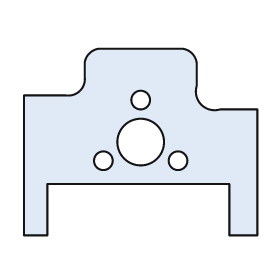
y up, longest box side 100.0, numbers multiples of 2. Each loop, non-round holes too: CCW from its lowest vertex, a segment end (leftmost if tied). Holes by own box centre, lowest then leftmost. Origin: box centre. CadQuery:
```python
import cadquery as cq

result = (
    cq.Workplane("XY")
    .moveTo(-50.0, -40.0)
    .lineTo(-40.0, -40.0)
    .lineTo(-40.0, -18.0)
    .lineTo(38.0, -18.0)
    .lineTo(38.0, -40.0)
    .lineTo(50.0, -40.0)
    .lineTo(50.0, 14.0)
    .lineTo(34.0, 14.0)
    .threePointArc((26.0, 16.0), (24.0, 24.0))
    .lineTo(24.0, 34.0)
    .threePointArc((22.0, 38.0), (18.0, 40.0))
    .lineTo(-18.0, 40.0)
    .threePointArc((-22.0, 38.0), (-24.0, 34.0))
    .lineTo(-24.0, 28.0)
    .threePointArc((-26.0, 22.0), (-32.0, 20.0))
    .lineTo(-50.0, 20.0)
    .close()
    .moveTo(-16.0, -8.0)
    .circle(4.0)
    .moveTo(16.0, -8.0)
    .circle(4.0)
    .moveTo(0.0, 0.0)
    .circle(10.0)
    .moveTo(0.0, 18.0)
    .circle(4.0)
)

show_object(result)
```